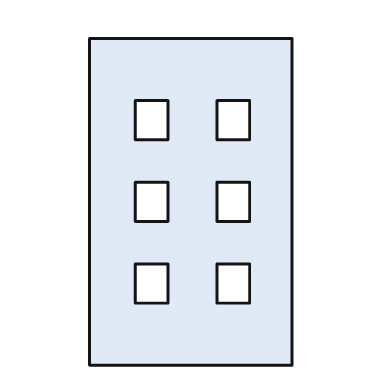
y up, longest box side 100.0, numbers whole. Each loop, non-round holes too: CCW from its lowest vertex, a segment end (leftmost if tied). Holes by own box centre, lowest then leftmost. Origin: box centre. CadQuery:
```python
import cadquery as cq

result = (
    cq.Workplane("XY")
    .moveTo(-31.0, -50.0)
    .lineTo(31.0, -50.0)
    .lineTo(31.0, 50.0)
    .lineTo(-31.0, 50.0)
    .close()
    .moveTo(-17.0, -31.0)
    .lineTo(-7.0, -31.0)
    .lineTo(-7.0, -19.0)
    .lineTo(-17.0, -19.0)
    .close()
    .moveTo(8.0, -31.0)
    .lineTo(18.0, -31.0)
    .lineTo(18.0, -19.0)
    .lineTo(8.0, -19.0)
    .close()
    .moveTo(-17.0, -6.0)
    .lineTo(-7.0, -6.0)
    .lineTo(-7.0, 6.0)
    .lineTo(-17.0, 6.0)
    .close()
    .moveTo(8.0, -6.0)
    .lineTo(18.0, -6.0)
    .lineTo(18.0, 6.0)
    .lineTo(8.0, 6.0)
    .close()
    .moveTo(-17.0, 19.0)
    .lineTo(-7.0, 19.0)
    .lineTo(-7.0, 31.0)
    .lineTo(-17.0, 31.0)
    .close()
    .moveTo(8.0, 19.0)
    .lineTo(18.0, 19.0)
    .lineTo(18.0, 31.0)
    .lineTo(8.0, 31.0)
    .close()
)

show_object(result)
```